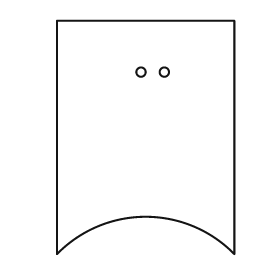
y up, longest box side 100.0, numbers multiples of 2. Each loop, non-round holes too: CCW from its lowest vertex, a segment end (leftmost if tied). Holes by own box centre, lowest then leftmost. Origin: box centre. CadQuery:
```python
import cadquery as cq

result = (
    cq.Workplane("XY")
    .moveTo(-38.0, -50.0)
    .threePointArc((0.0, -34.0), (38.0, -50.0))
    .lineTo(38.0, 50.0)
    .lineTo(-38.0, 50.0)
    .close()
    .moveTo(-2.0, 28.0)
    .circle(2.0)
    .moveTo(8.0, 28.0)
    .circle(2.0)
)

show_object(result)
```